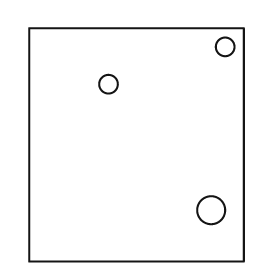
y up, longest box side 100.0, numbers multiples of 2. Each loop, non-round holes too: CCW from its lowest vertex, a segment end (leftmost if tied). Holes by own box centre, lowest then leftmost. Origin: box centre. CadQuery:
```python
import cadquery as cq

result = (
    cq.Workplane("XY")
    .moveTo(-46.0, -50.0)
    .lineTo(46.0, -50.0)
    .lineTo(46.0, 50.0)
    .lineTo(-46.0, 50.0)
    .close()
    .moveTo(32.0, -28.0)
    .circle(6.0)
    .moveTo(-12.0, 26.0)
    .circle(4.0)
    .moveTo(38.0, 42.0)
    .circle(4.0)
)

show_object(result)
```